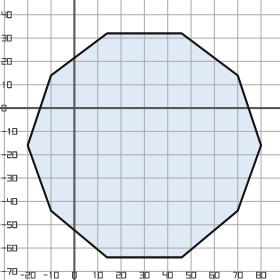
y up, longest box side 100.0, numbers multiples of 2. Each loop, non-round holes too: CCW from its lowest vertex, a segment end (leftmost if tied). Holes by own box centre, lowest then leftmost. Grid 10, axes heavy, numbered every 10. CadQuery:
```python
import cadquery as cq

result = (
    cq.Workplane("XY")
    .moveTo(14.0, -64.0)
    .lineTo(46.0, -64.0)
    .lineTo(70.0, -44.0)
    .lineTo(80.0, -16.0)
    .lineTo(70.0, 14.0)
    .lineTo(46.0, 32.0)
    .lineTo(14.0, 32.0)
    .lineTo(-10.0, 14.0)
    .lineTo(-20.0, -16.0)
    .lineTo(-10.0, -44.0)
    .close()
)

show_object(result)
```